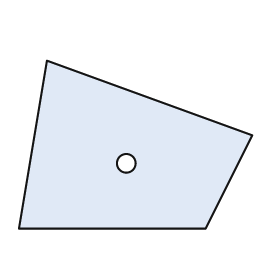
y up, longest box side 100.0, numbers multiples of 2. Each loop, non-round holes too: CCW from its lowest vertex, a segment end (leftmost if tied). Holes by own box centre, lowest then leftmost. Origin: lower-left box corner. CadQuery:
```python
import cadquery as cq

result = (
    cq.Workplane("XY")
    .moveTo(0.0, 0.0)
    .lineTo(80.0, 0.0)
    .lineTo(100.0, 40.0)
    .lineTo(12.0, 72.0)
    .close()
    .moveTo(46.0, 28.0)
    .circle(4.0)
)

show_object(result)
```